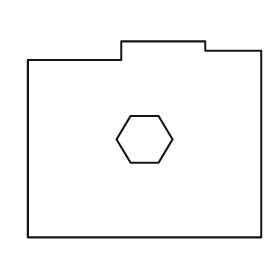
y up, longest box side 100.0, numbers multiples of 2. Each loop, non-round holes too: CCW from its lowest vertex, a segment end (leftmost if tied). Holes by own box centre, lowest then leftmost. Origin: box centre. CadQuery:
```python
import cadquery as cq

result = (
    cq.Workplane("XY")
    .moveTo(-50.0, -42.0)
    .lineTo(50.0, -42.0)
    .lineTo(50.0, 38.0)
    .lineTo(26.0, 38.0)
    .lineTo(26.0, 42.0)
    .lineTo(-10.0, 42.0)
    .lineTo(-10.0, 34.0)
    .lineTo(-50.0, 34.0)
    .close()
    .moveTo(-6.0, -10.0)
    .lineTo(6.0, -10.0)
    .lineTo(12.0, 0.0)
    .lineTo(6.0, 10.0)
    .lineTo(-6.0, 10.0)
    .lineTo(-12.0, 0.0)
    .close()
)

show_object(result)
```